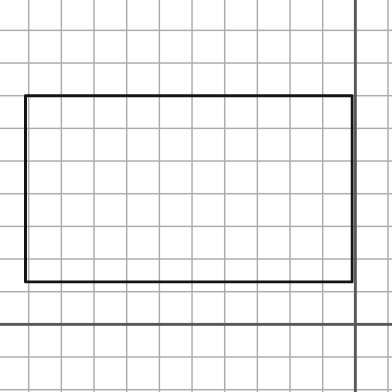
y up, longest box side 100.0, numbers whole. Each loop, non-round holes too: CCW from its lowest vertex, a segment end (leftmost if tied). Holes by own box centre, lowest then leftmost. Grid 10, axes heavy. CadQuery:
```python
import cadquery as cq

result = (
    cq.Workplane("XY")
    .moveTo(-101.0, 13.0)
    .lineTo(-1.0, 13.0)
    .lineTo(-1.0, 70.0)
    .lineTo(-101.0, 70.0)
    .close()
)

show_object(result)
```